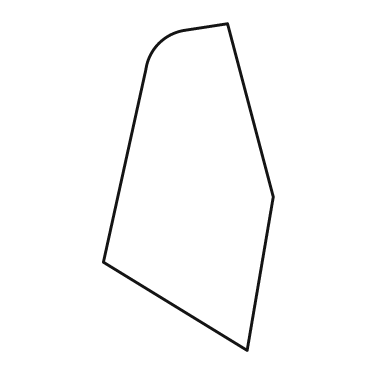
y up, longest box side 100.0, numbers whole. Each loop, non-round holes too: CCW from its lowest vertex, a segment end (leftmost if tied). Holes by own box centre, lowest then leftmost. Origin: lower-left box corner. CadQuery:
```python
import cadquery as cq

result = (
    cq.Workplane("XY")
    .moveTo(44.0, 0.0)
    .lineTo(52.0, 47.0)
    .lineTo(38.0, 100.0)
    .lineTo(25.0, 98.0)
    .threePointArc((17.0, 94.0), (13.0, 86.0))
    .lineTo(0.0, 27.0)
    .close()
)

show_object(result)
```